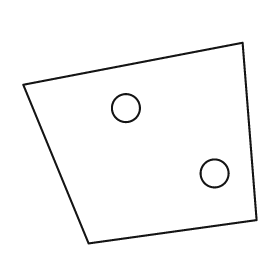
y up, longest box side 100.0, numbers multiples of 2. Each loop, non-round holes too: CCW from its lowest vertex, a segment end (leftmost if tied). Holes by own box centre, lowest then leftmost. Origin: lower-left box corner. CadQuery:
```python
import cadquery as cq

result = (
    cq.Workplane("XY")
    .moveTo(28.0, 0.0)
    .lineTo(100.0, 10.0)
    .lineTo(94.0, 86.0)
    .lineTo(0.0, 68.0)
    .close()
    .moveTo(82.0, 30.0)
    .circle(6.0)
    .moveTo(44.0, 58.0)
    .circle(6.0)
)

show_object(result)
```